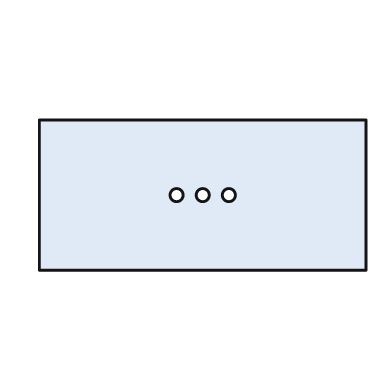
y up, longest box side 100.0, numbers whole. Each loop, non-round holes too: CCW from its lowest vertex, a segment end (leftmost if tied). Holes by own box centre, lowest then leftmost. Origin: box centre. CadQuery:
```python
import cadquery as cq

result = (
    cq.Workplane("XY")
    .moveTo(-50.0, -23.0)
    .lineTo(50.0, -23.0)
    .lineTo(50.0, 23.0)
    .lineTo(-50.0, 23.0)
    .close()
    .moveTo(-8.0, 0.0)
    .circle(2.0)
    .moveTo(0.0, 0.0)
    .circle(2.0)
    .moveTo(8.0, 0.0)
    .circle(2.0)
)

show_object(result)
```